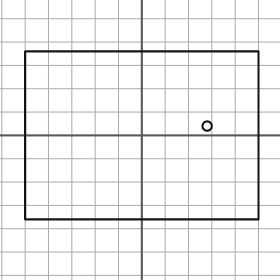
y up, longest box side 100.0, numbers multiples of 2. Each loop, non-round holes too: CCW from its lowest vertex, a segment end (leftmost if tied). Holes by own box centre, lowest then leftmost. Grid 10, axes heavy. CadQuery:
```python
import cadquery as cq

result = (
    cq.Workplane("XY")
    .moveTo(-50.0, -36.0)
    .lineTo(50.0, -36.0)
    .lineTo(50.0, 36.0)
    .lineTo(-50.0, 36.0)
    .close()
    .moveTo(28.0, 4.0)
    .circle(2.0)
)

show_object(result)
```